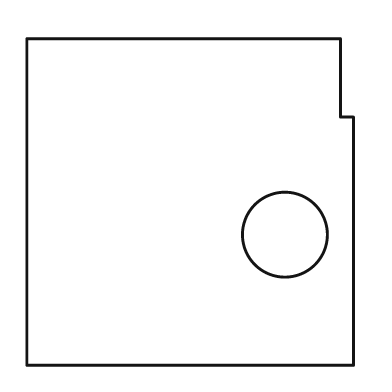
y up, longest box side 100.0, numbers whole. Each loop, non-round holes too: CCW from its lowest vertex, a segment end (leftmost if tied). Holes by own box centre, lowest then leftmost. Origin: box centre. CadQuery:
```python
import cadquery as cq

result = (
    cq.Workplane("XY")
    .moveTo(-50.0, -50.0)
    .lineTo(50.0, -50.0)
    .lineTo(50.0, 26.0)
    .lineTo(46.0, 26.0)
    .lineTo(46.0, 50.0)
    .lineTo(-50.0, 50.0)
    .close()
    .moveTo(29.0, -10.0)
    .circle(13.0)
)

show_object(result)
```